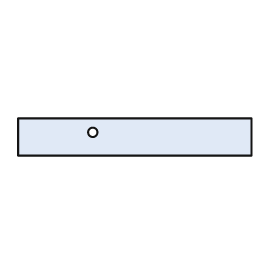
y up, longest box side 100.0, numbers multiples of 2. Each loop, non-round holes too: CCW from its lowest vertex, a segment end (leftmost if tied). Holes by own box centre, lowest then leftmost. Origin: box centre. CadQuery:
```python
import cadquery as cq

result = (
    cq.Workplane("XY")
    .moveTo(-50.0, -8.0)
    .lineTo(50.0, -8.0)
    .lineTo(50.0, 8.0)
    .lineTo(-50.0, 8.0)
    .close()
    .moveTo(-18.0, 2.0)
    .circle(2.0)
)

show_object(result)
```